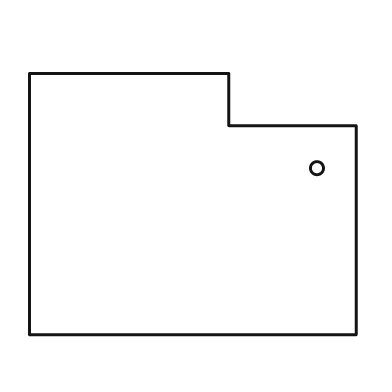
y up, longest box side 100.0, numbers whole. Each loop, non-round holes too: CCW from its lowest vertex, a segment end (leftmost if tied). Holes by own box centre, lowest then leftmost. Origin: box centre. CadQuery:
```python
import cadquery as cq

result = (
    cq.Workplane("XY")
    .moveTo(-50.0, -40.0)
    .lineTo(50.0, -40.0)
    .lineTo(50.0, 24.0)
    .lineTo(11.0, 24.0)
    .lineTo(11.0, 40.0)
    .lineTo(-50.0, 40.0)
    .close()
    .moveTo(38.0, 11.0)
    .circle(2.0)
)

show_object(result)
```